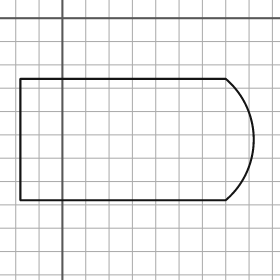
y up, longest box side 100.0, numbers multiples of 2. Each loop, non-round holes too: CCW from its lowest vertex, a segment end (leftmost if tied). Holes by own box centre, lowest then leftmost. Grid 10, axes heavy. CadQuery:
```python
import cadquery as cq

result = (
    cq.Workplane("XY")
    .moveTo(-18.0, -78.0)
    .lineTo(70.0, -78.0)
    .threePointArc((82.0, -52.0), (70.0, -26.0))
    .lineTo(-18.0, -26.0)
    .close()
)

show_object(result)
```